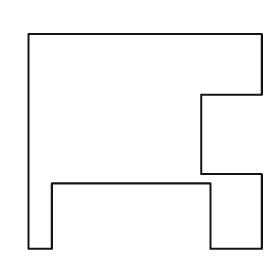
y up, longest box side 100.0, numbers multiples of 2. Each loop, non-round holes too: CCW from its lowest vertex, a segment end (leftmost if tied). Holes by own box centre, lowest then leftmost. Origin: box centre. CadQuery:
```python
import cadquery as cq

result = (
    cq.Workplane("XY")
    .moveTo(-50.0, -46.0)
    .lineTo(-40.0, -46.0)
    .lineTo(-40.0, -18.0)
    .lineTo(28.0, -18.0)
    .lineTo(28.0, -46.0)
    .lineTo(50.0, -46.0)
    .lineTo(50.0, -14.0)
    .lineTo(24.0, -14.0)
    .lineTo(24.0, 20.0)
    .lineTo(50.0, 20.0)
    .lineTo(50.0, 46.0)
    .lineTo(-50.0, 46.0)
    .close()
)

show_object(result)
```